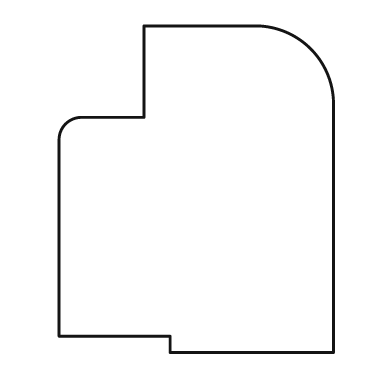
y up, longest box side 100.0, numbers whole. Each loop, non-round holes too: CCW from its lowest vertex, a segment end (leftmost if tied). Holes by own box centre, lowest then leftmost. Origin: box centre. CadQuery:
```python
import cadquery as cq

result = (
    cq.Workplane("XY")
    .moveTo(-8.0, -50.0)
    .lineTo(42.0, -50.0)
    .lineTo(42.0, 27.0)
    .threePointArc((35.0, 43.0), (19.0, 50.0))
    .lineTo(-16.0, 50.0)
    .lineTo(-16.0, 22.0)
    .lineTo(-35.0, 22.0)
    .threePointArc((-40.0, 20.0), (-42.0, 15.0))
    .lineTo(-42.0, -45.0)
    .lineTo(-8.0, -45.0)
    .close()
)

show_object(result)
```